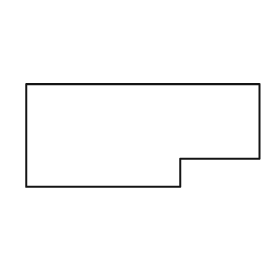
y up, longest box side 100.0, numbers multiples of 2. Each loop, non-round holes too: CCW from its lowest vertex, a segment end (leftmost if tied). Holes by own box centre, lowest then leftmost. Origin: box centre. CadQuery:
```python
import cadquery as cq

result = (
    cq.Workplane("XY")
    .moveTo(-50.0, -22.0)
    .lineTo(16.0, -22.0)
    .lineTo(16.0, -10.0)
    .lineTo(50.0, -10.0)
    .lineTo(50.0, 22.0)
    .lineTo(-50.0, 22.0)
    .close()
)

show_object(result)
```